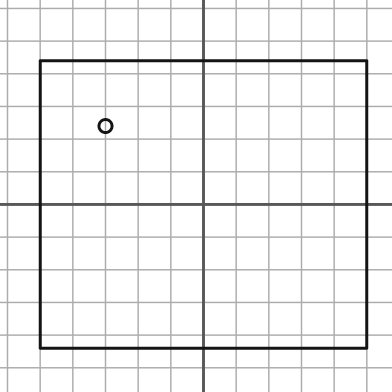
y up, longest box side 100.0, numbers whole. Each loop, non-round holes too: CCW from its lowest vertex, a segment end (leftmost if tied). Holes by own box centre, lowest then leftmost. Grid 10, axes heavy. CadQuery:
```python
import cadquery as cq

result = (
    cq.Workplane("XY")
    .moveTo(-50.0, -44.0)
    .lineTo(50.0, -44.0)
    .lineTo(50.0, 44.0)
    .lineTo(-50.0, 44.0)
    .close()
    .moveTo(-30.0, 24.0)
    .circle(2.0)
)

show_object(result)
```